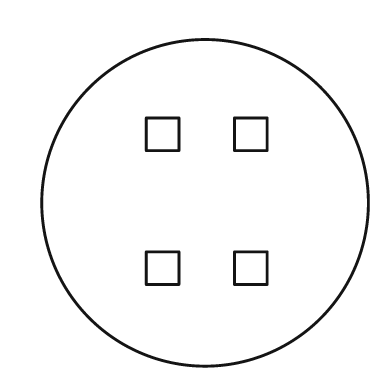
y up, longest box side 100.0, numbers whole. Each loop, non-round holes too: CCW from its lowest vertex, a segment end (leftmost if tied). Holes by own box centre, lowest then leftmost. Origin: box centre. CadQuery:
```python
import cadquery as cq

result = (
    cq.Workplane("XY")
    .moveTo(0.0, 0.0)
    .circle(50.0)
    .moveTo(-18.0, -25.0)
    .lineTo(-8.0, -25.0)
    .lineTo(-8.0, -15.0)
    .lineTo(-18.0, -15.0)
    .close()
    .moveTo(9.0, -25.0)
    .lineTo(19.0, -25.0)
    .lineTo(19.0, -15.0)
    .lineTo(9.0, -15.0)
    .close()
    .moveTo(-18.0, 16.0)
    .lineTo(-8.0, 16.0)
    .lineTo(-8.0, 26.0)
    .lineTo(-18.0, 26.0)
    .close()
    .moveTo(9.0, 16.0)
    .lineTo(19.0, 16.0)
    .lineTo(19.0, 26.0)
    .lineTo(9.0, 26.0)
    .close()
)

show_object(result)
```